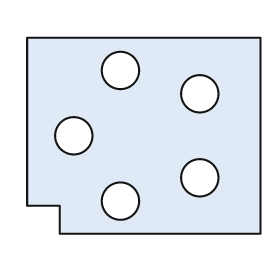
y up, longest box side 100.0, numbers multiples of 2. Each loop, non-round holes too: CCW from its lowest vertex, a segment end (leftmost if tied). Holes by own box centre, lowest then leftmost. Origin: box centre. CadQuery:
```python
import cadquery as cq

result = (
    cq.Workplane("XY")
    .moveTo(-36.0, -42.0)
    .lineTo(50.0, -42.0)
    .lineTo(50.0, 42.0)
    .lineTo(-50.0, 42.0)
    .lineTo(-50.0, -30.0)
    .lineTo(-36.0, -30.0)
    .close()
    .moveTo(-10.0, -28.0)
    .circle(8.0)
    .moveTo(24.0, -18.0)
    .circle(8.0)
    .moveTo(-30.0, 0.0)
    .circle(8.0)
    .moveTo(24.0, 18.0)
    .circle(8.0)
    .moveTo(-10.0, 28.0)
    .circle(8.0)
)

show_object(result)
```